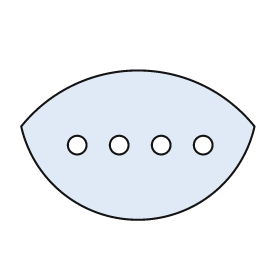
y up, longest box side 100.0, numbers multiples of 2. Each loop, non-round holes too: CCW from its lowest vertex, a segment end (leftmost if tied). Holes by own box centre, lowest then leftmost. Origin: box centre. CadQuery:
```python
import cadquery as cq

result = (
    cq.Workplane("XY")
    .moveTo(-50.0, 8.0)
    .threePointArc((0.0, -32.0), (50.0, 8.0))
    .threePointArc((0.0, 32.0), (-50.0, 8.0))
    .close()
    .moveTo(-26.0, 0.0)
    .circle(4.0)
    .moveTo(-8.0, 0.0)
    .circle(4.0)
    .moveTo(10.0, 0.0)
    .circle(4.0)
    .moveTo(28.0, 0.0)
    .circle(4.0)
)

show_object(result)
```